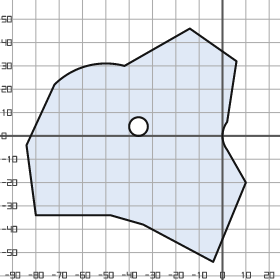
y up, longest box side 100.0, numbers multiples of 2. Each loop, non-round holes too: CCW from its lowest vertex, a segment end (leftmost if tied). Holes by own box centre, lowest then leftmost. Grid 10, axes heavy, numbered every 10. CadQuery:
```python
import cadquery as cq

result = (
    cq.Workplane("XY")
    .moveTo(-4.0, -54.0)
    .lineTo(10.0, -20.0)
    .lineTo(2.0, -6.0)
    .threePointArc((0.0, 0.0), (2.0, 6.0))
    .lineTo(6.0, 32.0)
    .lineTo(-14.0, 46.0)
    .lineTo(-42.0, 30.0)
    .threePointArc((-58.0, 30.0), (-72.0, 22.0))
    .lineTo(-84.0, -4.0)
    .lineTo(-80.0, -34.0)
    .lineTo(-48.0, -34.0)
    .lineTo(-34.0, -38.0)
    .close()
    .moveTo(-36.0, 4.0)
    .circle(4.0)
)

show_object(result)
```